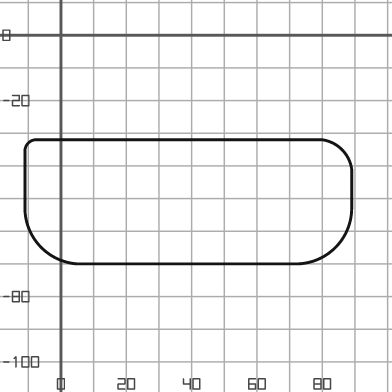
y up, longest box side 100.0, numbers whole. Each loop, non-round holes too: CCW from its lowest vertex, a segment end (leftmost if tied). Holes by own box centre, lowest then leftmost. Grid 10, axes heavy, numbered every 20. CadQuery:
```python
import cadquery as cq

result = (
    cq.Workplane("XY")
    .moveTo(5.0, -70.0)
    .lineTo(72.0, -70.0)
    .threePointArc((84.0, -65.0), (89.0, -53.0))
    .lineTo(89.0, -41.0)
    .threePointArc((86.0, -35.0), (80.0, -32.0))
    .lineTo(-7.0, -32.0)
    .threePointArc((-10.0, -33.0), (-11.0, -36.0))
    .lineTo(-11.0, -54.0)
    .threePointArc((-6.0, -65.0), (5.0, -70.0))
    .close()
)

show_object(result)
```